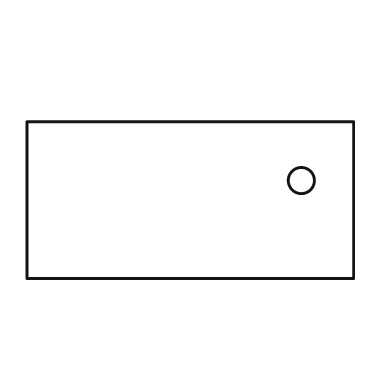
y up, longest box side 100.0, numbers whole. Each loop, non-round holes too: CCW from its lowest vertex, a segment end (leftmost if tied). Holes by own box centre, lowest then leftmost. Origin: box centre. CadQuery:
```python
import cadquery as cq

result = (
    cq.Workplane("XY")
    .moveTo(-50.0, -24.0)
    .lineTo(50.0, -24.0)
    .lineTo(50.0, 24.0)
    .lineTo(-50.0, 24.0)
    .close()
    .moveTo(34.0, 6.0)
    .circle(4.0)
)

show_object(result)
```